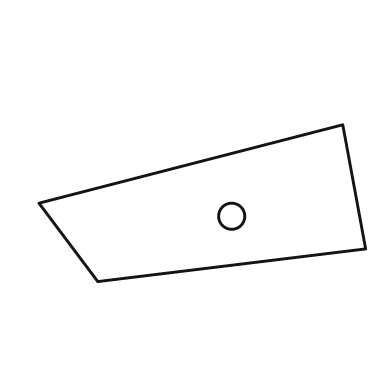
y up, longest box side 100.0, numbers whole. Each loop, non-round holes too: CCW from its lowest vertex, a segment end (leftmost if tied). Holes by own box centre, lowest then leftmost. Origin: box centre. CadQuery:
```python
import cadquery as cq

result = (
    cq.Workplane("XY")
    .moveTo(-32.0, -24.0)
    .lineTo(50.0, -14.0)
    .lineTo(43.0, 24.0)
    .lineTo(-50.0, 0.0)
    .close()
    .moveTo(9.0, -4.0)
    .circle(4.0)
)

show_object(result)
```